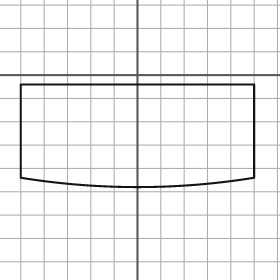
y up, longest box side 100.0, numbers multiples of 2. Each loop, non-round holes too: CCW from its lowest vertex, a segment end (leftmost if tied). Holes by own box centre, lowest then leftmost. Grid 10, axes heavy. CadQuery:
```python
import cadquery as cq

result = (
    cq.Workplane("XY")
    .moveTo(-50.0, -44.0)
    .threePointArc((0.0, -48.0), (50.0, -44.0))
    .lineTo(50.0, -4.0)
    .lineTo(-50.0, -4.0)
    .close()
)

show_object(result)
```